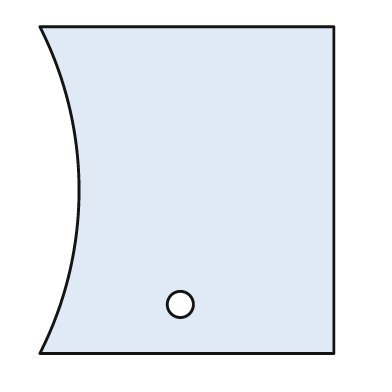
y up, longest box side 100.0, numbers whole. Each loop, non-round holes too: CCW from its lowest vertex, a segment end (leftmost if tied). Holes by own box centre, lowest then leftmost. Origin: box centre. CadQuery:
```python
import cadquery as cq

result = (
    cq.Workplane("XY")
    .moveTo(-45.0, -50.0)
    .lineTo(45.0, -50.0)
    .lineTo(45.0, 50.0)
    .lineTo(-45.0, 50.0)
    .threePointArc((-33.0, 0.0), (-45.0, -50.0))
    .close()
    .moveTo(-2.0, -35.0)
    .circle(4.0)
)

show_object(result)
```